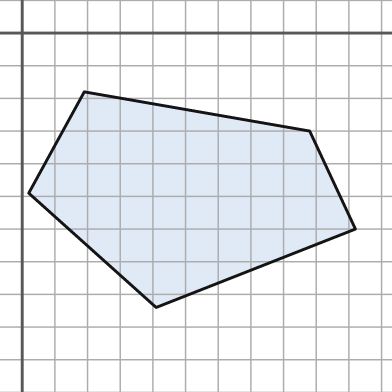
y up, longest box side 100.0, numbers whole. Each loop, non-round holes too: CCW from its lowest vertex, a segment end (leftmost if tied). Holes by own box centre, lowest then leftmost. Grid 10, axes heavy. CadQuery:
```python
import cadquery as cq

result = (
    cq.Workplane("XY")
    .moveTo(41.0, -84.0)
    .lineTo(102.0, -60.0)
    .lineTo(88.0, -30.0)
    .lineTo(19.0, -18.0)
    .lineTo(2.0, -49.0)
    .close()
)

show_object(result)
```